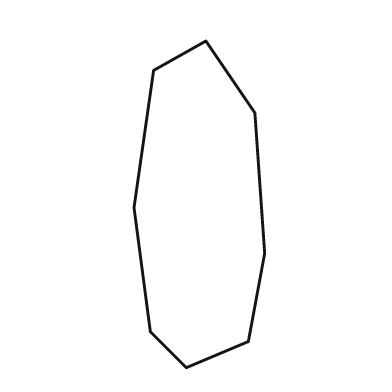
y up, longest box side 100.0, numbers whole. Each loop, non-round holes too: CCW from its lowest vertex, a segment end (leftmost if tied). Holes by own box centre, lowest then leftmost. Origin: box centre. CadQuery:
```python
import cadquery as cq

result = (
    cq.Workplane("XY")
    .moveTo(-4.0, -50.0)
    .lineTo(15.0, -42.0)
    .lineTo(20.0, -15.0)
    .lineTo(17.0, 28.0)
    .lineTo(2.0, 50.0)
    .lineTo(-14.0, 41.0)
    .lineTo(-20.0, -1.0)
    .lineTo(-15.0, -39.0)
    .close()
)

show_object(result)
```